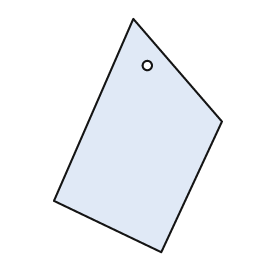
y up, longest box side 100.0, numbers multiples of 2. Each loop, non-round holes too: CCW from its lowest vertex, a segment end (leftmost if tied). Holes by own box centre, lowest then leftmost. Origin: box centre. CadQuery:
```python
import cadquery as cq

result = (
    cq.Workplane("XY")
    .moveTo(10.0, -50.0)
    .lineTo(36.0, 6.0)
    .lineTo(-2.0, 50.0)
    .lineTo(-36.0, -28.0)
    .close()
    .moveTo(4.0, 30.0)
    .circle(2.0)
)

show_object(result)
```